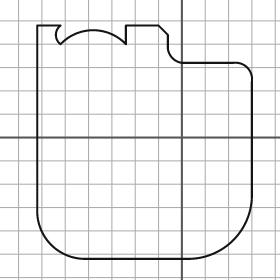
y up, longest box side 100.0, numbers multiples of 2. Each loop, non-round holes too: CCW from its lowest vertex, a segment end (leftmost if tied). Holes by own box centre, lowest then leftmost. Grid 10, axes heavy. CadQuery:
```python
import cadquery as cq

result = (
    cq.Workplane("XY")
    .moveTo(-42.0, -52.0)
    .lineTo(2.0, -52.0)
    .threePointArc((22.0, -44.0), (30.0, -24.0))
    .lineTo(30.0, 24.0)
    .threePointArc((28.0, 30.0), (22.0, 32.0))
    .lineTo(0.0, 32.0)
    .threePointArc((-4.0, 34.0), (-6.0, 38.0))
    .lineTo(-6.0, 44.0)
    .lineTo(-10.0, 48.0)
    .lineTo(-24.0, 48.0)
    .lineTo(-24.0, 40.0)
    .threePointArc((-38.0, 46.0), (-52.0, 40.0))
    .threePointArc((-54.0, 44.0), (-52.0, 48.0))
    .lineTo(-62.0, 48.0)
    .lineTo(-62.0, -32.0)
    .threePointArc((-56.0, -46.0), (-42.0, -52.0))
    .close()
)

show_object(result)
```